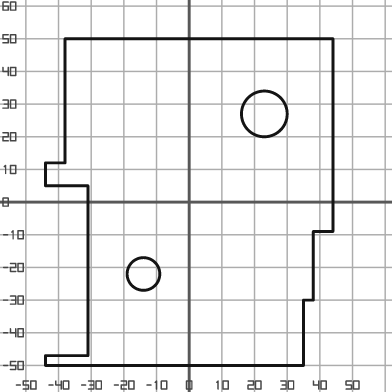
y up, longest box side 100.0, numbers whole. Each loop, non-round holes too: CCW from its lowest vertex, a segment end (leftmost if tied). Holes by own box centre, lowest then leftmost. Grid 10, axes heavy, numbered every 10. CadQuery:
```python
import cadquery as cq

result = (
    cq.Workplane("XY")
    .moveTo(-44.0, -50.0)
    .lineTo(35.0, -50.0)
    .lineTo(35.0, -30.0)
    .lineTo(38.0, -30.0)
    .lineTo(38.0, -9.0)
    .lineTo(44.0, -9.0)
    .lineTo(44.0, 50.0)
    .lineTo(-38.0, 50.0)
    .lineTo(-38.0, 12.0)
    .lineTo(-44.0, 12.0)
    .lineTo(-44.0, 5.0)
    .lineTo(-31.0, 5.0)
    .lineTo(-31.0, -47.0)
    .lineTo(-44.0, -47.0)
    .close()
    .moveTo(-14.0, -22.0)
    .circle(5.0)
    .moveTo(23.0, 27.0)
    .circle(7.0)
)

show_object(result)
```